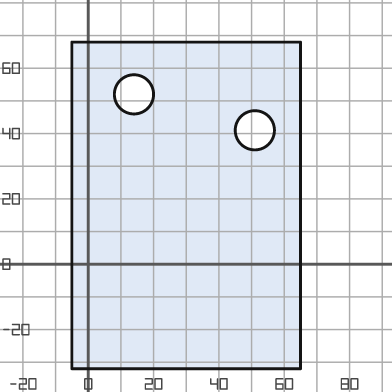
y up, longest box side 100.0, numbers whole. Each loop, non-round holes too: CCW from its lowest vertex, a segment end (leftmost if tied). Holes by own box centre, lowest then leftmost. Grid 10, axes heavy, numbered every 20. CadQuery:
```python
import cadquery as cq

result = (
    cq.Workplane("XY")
    .moveTo(-5.0, -32.0)
    .lineTo(65.0, -32.0)
    .lineTo(65.0, 68.0)
    .lineTo(-5.0, 68.0)
    .close()
    .moveTo(51.0, 41.0)
    .circle(6.0)
    .moveTo(14.0, 52.0)
    .circle(6.0)
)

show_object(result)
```